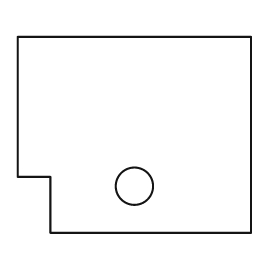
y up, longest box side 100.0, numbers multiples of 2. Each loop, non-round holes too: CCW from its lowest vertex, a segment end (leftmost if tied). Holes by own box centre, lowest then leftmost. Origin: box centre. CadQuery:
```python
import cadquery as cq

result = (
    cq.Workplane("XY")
    .moveTo(-36.0, -42.0)
    .lineTo(50.0, -42.0)
    .lineTo(50.0, 42.0)
    .lineTo(-50.0, 42.0)
    .lineTo(-50.0, -18.0)
    .lineTo(-36.0, -18.0)
    .close()
    .moveTo(0.0, -22.0)
    .circle(8.0)
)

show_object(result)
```